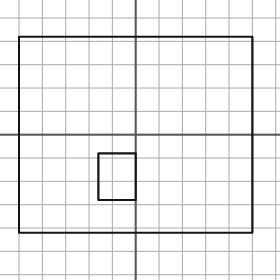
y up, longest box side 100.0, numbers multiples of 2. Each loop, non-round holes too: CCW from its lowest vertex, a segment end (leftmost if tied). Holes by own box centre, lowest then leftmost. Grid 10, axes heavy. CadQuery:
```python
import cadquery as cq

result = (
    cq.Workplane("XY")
    .moveTo(-50.0, -42.0)
    .lineTo(50.0, -42.0)
    .lineTo(50.0, 42.0)
    .lineTo(-50.0, 42.0)
    .close()
    .moveTo(-16.0, -28.0)
    .lineTo(0.0, -28.0)
    .lineTo(0.0, -8.0)
    .lineTo(-16.0, -8.0)
    .close()
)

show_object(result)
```